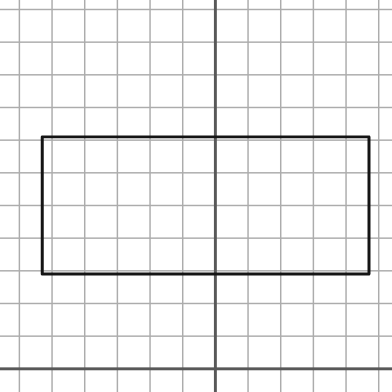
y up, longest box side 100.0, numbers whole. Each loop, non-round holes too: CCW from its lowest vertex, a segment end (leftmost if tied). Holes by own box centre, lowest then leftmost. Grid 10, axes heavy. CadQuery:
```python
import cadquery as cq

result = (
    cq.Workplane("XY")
    .moveTo(-53.0, 29.0)
    .lineTo(47.0, 29.0)
    .lineTo(47.0, 71.0)
    .lineTo(-53.0, 71.0)
    .close()
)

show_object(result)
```